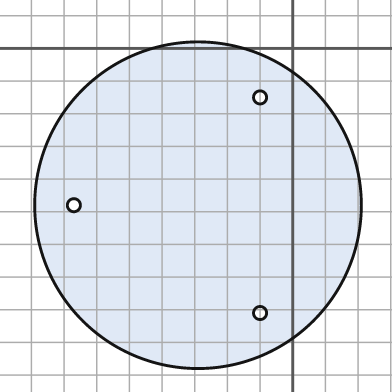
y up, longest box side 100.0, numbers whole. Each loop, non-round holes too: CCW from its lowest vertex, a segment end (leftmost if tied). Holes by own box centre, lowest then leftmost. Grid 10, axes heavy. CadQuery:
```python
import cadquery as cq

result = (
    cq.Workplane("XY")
    .moveTo(-29.0, -48.0)
    .circle(50.0)
    .moveTo(-10.0, -81.0)
    .circle(2.0)
    .moveTo(-67.0, -48.0)
    .circle(2.0)
    .moveTo(-10.0, -15.0)
    .circle(2.0)
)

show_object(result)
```